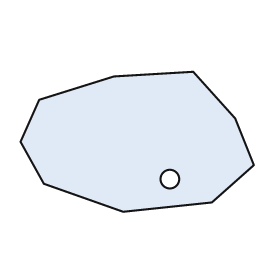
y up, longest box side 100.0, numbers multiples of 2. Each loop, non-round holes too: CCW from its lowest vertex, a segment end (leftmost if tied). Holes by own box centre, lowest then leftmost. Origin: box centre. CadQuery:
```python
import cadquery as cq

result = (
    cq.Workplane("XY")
    .moveTo(-6.0, -30.0)
    .lineTo(32.0, -26.0)
    .lineTo(50.0, -10.0)
    .lineTo(42.0, 10.0)
    .lineTo(24.0, 30.0)
    .lineTo(-10.0, 28.0)
    .lineTo(-42.0, 18.0)
    .lineTo(-50.0, 0.0)
    .lineTo(-40.0, -18.0)
    .close()
    .moveTo(14.0, -16.0)
    .circle(4.0)
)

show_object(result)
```